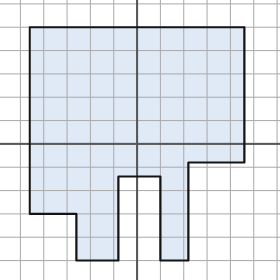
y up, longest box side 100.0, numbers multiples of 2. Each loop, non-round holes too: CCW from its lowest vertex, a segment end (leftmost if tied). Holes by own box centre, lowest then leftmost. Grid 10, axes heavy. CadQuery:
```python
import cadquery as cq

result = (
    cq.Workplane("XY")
    .moveTo(-26.0, -50.0)
    .lineTo(-8.0, -50.0)
    .lineTo(-8.0, -14.0)
    .lineTo(10.0, -14.0)
    .lineTo(10.0, -50.0)
    .lineTo(22.0, -50.0)
    .lineTo(22.0, -8.0)
    .lineTo(46.0, -8.0)
    .lineTo(46.0, 50.0)
    .lineTo(-46.0, 50.0)
    .lineTo(-46.0, -30.0)
    .lineTo(-26.0, -30.0)
    .close()
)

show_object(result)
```